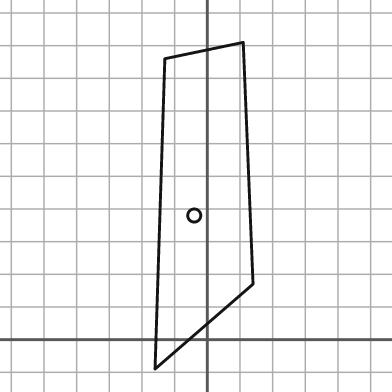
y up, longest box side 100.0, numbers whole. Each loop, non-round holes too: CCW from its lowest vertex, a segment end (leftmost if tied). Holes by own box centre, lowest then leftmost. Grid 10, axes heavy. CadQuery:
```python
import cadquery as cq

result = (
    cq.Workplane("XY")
    .moveTo(-16.0, -9.0)
    .lineTo(14.0, 17.0)
    .lineTo(11.0, 91.0)
    .lineTo(-13.0, 86.0)
    .close()
    .moveTo(-4.0, 38.0)
    .circle(2.0)
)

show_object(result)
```